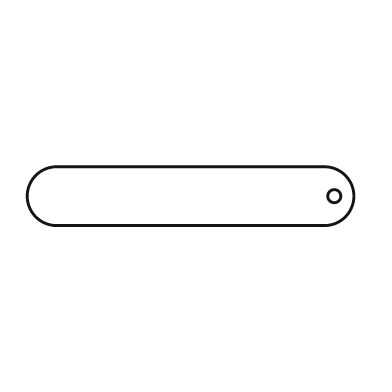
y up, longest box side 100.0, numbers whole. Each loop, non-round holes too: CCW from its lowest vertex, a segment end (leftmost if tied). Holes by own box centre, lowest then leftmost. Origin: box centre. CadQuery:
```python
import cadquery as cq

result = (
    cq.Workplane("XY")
    .moveTo(-41.0, -9.0)
    .lineTo(41.0, -9.0)
    .threePointArc((50.0, 0.0), (41.0, 9.0))
    .lineTo(-41.0, 9.0)
    .threePointArc((-50.0, 0.0), (-41.0, -9.0))
    .close()
    .moveTo(44.0, 0.0)
    .circle(2.0)
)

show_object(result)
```